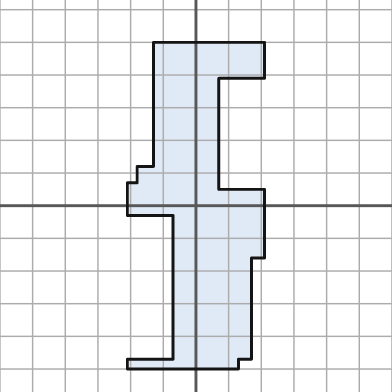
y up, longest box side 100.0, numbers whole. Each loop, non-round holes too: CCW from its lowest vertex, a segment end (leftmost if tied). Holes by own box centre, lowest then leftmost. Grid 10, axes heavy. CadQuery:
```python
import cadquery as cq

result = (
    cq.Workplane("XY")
    .moveTo(-21.0, -50.0)
    .lineTo(13.0, -50.0)
    .lineTo(13.0, -47.0)
    .lineTo(17.0, -47.0)
    .lineTo(17.0, -16.0)
    .lineTo(21.0, -16.0)
    .lineTo(21.0, 5.0)
    .lineTo(7.0, 5.0)
    .lineTo(7.0, 39.0)
    .lineTo(21.0, 39.0)
    .lineTo(21.0, 50.0)
    .lineTo(-13.0, 50.0)
    .lineTo(-13.0, 12.0)
    .lineTo(-18.0, 12.0)
    .lineTo(-18.0, 7.0)
    .lineTo(-21.0, 7.0)
    .lineTo(-21.0, -3.0)
    .lineTo(-7.0, -3.0)
    .lineTo(-7.0, -47.0)
    .lineTo(-21.0, -47.0)
    .close()
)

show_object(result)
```